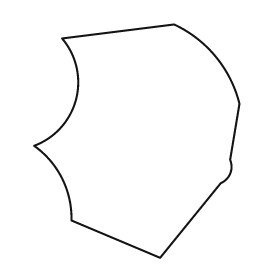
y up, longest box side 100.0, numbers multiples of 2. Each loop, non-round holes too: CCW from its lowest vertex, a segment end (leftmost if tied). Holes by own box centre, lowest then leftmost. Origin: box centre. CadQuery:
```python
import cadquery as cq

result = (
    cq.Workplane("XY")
    .moveTo(10.0, -50.0)
    .lineTo(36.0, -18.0)
    .threePointArc((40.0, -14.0), (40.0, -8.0))
    .lineTo(44.0, 16.0)
    .threePointArc((34.0, 36.0), (16.0, 50.0))
    .lineTo(-32.0, 44.0)
    .threePointArc((-26.0, 18.0), (-44.0, -2.0))
    .threePointArc((-32.0, -16.0), (-28.0, -34.0))
    .close()
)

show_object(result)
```